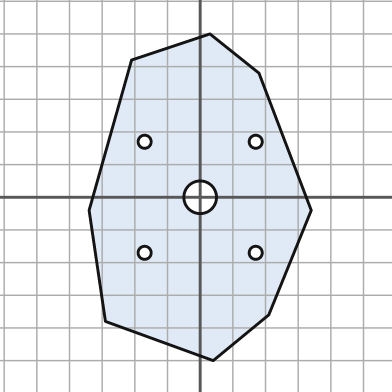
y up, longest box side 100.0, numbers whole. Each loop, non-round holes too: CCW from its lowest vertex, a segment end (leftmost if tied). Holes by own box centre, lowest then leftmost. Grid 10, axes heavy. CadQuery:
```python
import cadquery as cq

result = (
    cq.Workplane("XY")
    .moveTo(4.0, -50.0)
    .lineTo(21.0, -36.0)
    .lineTo(34.0, -4.0)
    .lineTo(18.0, 38.0)
    .lineTo(3.0, 50.0)
    .lineTo(-21.0, 42.0)
    .lineTo(-34.0, -4.0)
    .lineTo(-29.0, -38.0)
    .close()
    .moveTo(-17.0, -17.0)
    .circle(2.0)
    .moveTo(17.0, -17.0)
    .circle(2.0)
    .moveTo(0.0, 0.0)
    .circle(5.0)
    .moveTo(-17.0, 17.0)
    .circle(2.0)
    .moveTo(17.0, 17.0)
    .circle(2.0)
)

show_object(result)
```